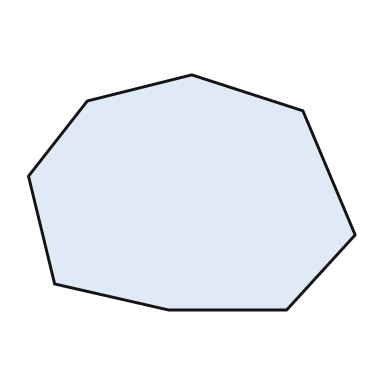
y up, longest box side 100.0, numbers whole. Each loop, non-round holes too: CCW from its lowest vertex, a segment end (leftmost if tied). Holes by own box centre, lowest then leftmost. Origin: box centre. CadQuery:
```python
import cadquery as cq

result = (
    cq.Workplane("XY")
    .moveTo(-7.0, -36.0)
    .lineTo(29.0, -36.0)
    .lineTo(50.0, -13.0)
    .lineTo(34.0, 25.0)
    .lineTo(0.0, 36.0)
    .lineTo(-32.0, 28.0)
    .lineTo(-50.0, 5.0)
    .lineTo(-42.0, -28.0)
    .close()
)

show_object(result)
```